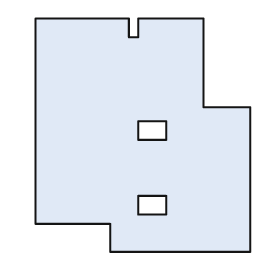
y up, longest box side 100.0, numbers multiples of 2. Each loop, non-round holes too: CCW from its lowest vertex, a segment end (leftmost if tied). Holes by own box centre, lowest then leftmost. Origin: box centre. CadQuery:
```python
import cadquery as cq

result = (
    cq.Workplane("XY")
    .moveTo(-14.0, -50.0)
    .lineTo(46.0, -50.0)
    .lineTo(46.0, 12.0)
    .lineTo(26.0, 12.0)
    .lineTo(26.0, 50.0)
    .lineTo(-2.0, 50.0)
    .lineTo(-2.0, 42.0)
    .lineTo(-6.0, 42.0)
    .lineTo(-6.0, 50.0)
    .lineTo(-46.0, 50.0)
    .lineTo(-46.0, -38.0)
    .lineTo(-14.0, -38.0)
    .close()
    .moveTo(-2.0, -34.0)
    .lineTo(10.0, -34.0)
    .lineTo(10.0, -26.0)
    .lineTo(-2.0, -26.0)
    .close()
    .moveTo(-2.0, -2.0)
    .lineTo(10.0, -2.0)
    .lineTo(10.0, 6.0)
    .lineTo(-2.0, 6.0)
    .close()
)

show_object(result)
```